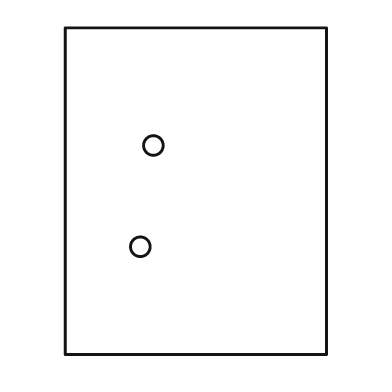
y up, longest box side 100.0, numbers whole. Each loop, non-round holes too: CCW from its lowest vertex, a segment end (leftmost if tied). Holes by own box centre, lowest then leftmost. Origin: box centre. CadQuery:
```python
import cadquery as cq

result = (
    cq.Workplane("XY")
    .moveTo(-40.0, -50.0)
    .lineTo(40.0, -50.0)
    .lineTo(40.0, 50.0)
    .lineTo(-40.0, 50.0)
    .close()
    .moveTo(-17.0, -17.0)
    .circle(3.0)
    .moveTo(-13.0, 14.0)
    .circle(3.0)
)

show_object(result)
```